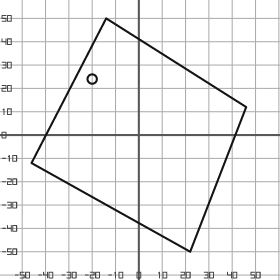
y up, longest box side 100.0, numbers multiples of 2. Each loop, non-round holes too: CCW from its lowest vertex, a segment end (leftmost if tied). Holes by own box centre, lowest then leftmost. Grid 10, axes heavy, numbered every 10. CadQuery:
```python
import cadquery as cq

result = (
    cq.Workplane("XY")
    .moveTo(22.0, -50.0)
    .lineTo(46.0, 12.0)
    .lineTo(-14.0, 50.0)
    .lineTo(-46.0, -12.0)
    .close()
    .moveTo(-20.0, 24.0)
    .circle(2.0)
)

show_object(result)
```